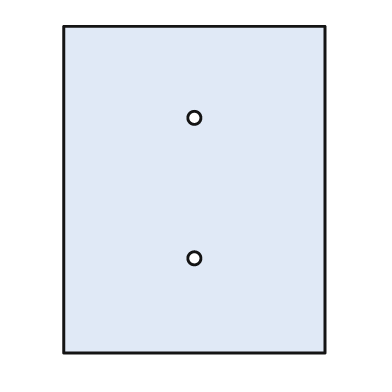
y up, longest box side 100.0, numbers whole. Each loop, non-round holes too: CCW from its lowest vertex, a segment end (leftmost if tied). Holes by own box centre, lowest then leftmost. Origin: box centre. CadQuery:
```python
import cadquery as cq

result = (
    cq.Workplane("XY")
    .moveTo(-40.0, -50.0)
    .lineTo(40.0, -50.0)
    .lineTo(40.0, 50.0)
    .lineTo(-40.0, 50.0)
    .close()
    .moveTo(0.0, -21.0)
    .circle(2.0)
    .moveTo(0.0, 22.0)
    .circle(2.0)
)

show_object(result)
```